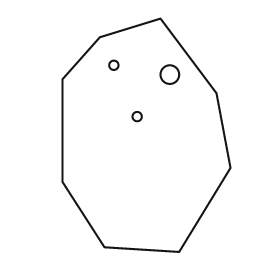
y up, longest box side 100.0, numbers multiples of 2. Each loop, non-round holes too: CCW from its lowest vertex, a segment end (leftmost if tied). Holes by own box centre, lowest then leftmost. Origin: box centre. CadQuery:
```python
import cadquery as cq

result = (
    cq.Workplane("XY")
    .moveTo(14.0, -50.0)
    .lineTo(36.0, -14.0)
    .lineTo(30.0, 18.0)
    .lineTo(6.0, 50.0)
    .lineTo(-20.0, 42.0)
    .lineTo(-36.0, 24.0)
    .lineTo(-36.0, -20.0)
    .lineTo(-18.0, -48.0)
    .close()
    .moveTo(-4.0, 8.0)
    .circle(2.0)
    .moveTo(10.0, 26.0)
    .circle(4.0)
    .moveTo(-14.0, 30.0)
    .circle(2.0)
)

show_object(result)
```